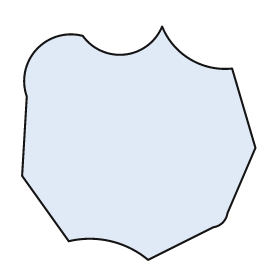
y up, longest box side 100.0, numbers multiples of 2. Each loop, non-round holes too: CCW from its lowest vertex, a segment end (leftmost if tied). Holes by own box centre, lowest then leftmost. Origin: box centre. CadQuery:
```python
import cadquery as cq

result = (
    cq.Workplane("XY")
    .moveTo(4.0, -50.0)
    .lineTo(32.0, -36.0)
    .threePointArc((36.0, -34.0), (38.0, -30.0))
    .lineTo(50.0, -2.0)
    .lineTo(40.0, 32.0)
    .threePointArc((22.0, 36.0), (10.0, 50.0))
    .threePointArc((-6.0, 38.0), (-24.0, 46.0))
    .threePointArc((-44.0, 40.0), (-48.0, 20.0))
    .lineTo(-50.0, -14.0)
    .lineTo(-30.0, -42.0)
    .threePointArc((-12.0, -42.0), (4.0, -50.0))
    .close()
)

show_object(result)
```